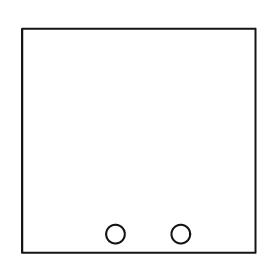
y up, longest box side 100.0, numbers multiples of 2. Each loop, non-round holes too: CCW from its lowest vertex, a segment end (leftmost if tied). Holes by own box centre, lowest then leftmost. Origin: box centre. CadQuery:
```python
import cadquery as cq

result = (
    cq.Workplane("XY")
    .moveTo(-50.0, -48.0)
    .lineTo(50.0, -48.0)
    .lineTo(50.0, 48.0)
    .lineTo(-50.0, 48.0)
    .close()
    .moveTo(-10.0, -40.0)
    .circle(4.0)
    .moveTo(18.0, -40.0)
    .circle(4.0)
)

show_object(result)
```